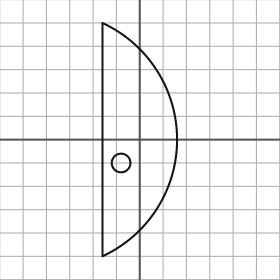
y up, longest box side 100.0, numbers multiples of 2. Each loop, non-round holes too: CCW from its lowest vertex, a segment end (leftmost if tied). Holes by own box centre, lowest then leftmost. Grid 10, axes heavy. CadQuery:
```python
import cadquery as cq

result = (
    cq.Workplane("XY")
    .moveTo(-16.0, -50.0)
    .threePointArc((16.0, 0.0), (-16.0, 50.0))
    .close()
    .moveTo(-8.0, -10.0)
    .circle(4.0)
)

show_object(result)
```